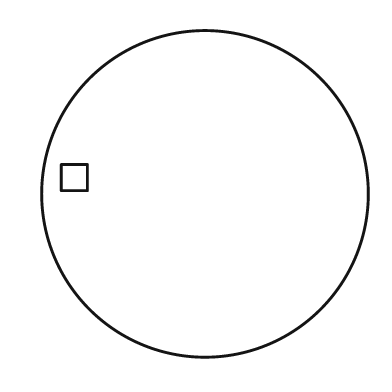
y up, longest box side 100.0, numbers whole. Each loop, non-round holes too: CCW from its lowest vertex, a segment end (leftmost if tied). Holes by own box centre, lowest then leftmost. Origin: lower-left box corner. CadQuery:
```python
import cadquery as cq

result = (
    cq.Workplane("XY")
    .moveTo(50.0, 50.0)
    .circle(50.0)
    .moveTo(6.0, 51.0)
    .lineTo(14.0, 51.0)
    .lineTo(14.0, 59.0)
    .lineTo(6.0, 59.0)
    .close()
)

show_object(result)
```